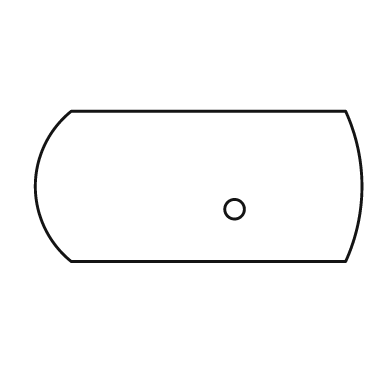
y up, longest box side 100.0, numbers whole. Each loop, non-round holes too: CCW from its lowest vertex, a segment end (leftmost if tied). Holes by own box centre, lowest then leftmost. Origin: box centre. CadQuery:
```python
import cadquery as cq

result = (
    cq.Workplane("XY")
    .moveTo(-39.0, -23.0)
    .lineTo(45.0, -23.0)
    .threePointArc((50.0, 0.0), (45.0, 23.0))
    .lineTo(-39.0, 23.0)
    .threePointArc((-50.0, 0.0), (-39.0, -23.0))
    .close()
    .moveTo(11.0, -7.0)
    .circle(3.0)
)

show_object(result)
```